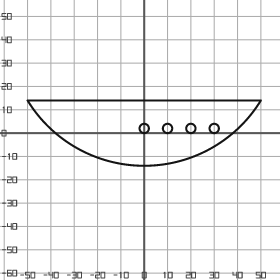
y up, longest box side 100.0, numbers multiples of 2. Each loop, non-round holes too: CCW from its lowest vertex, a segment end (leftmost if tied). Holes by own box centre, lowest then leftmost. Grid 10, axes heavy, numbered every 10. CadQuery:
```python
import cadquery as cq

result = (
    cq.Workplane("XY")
    .moveTo(-50.0, 14.0)
    .threePointArc((0.0, -14.0), (50.0, 14.0))
    .close()
    .moveTo(0.0, 2.0)
    .circle(2.0)
    .moveTo(10.0, 2.0)
    .circle(2.0)
    .moveTo(20.0, 2.0)
    .circle(2.0)
    .moveTo(30.0, 2.0)
    .circle(2.0)
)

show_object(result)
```